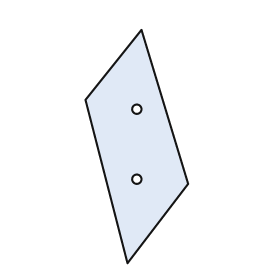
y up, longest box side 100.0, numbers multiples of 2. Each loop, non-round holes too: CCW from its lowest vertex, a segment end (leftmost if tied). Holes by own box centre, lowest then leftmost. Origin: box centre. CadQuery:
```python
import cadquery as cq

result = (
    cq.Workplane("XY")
    .moveTo(-4.0, -50.0)
    .lineTo(22.0, -16.0)
    .lineTo(2.0, 50.0)
    .lineTo(-22.0, 20.0)
    .close()
    .moveTo(0.0, -14.0)
    .circle(2.0)
    .moveTo(0.0, 16.0)
    .circle(2.0)
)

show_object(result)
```